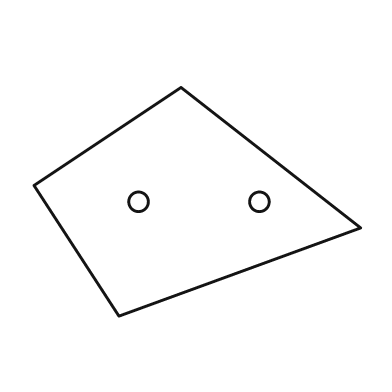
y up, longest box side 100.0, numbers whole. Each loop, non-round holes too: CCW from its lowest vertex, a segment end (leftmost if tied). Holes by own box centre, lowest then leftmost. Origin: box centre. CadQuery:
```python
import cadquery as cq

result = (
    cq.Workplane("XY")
    .moveTo(-24.0, -35.0)
    .lineTo(50.0, -8.0)
    .lineTo(-5.0, 35.0)
    .lineTo(-50.0, 5.0)
    .close()
    .moveTo(-18.0, 0.0)
    .circle(3.0)
    .moveTo(19.0, 0.0)
    .circle(3.0)
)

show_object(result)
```